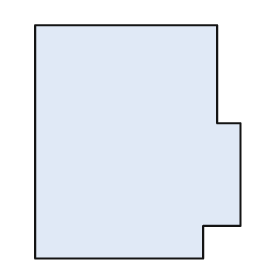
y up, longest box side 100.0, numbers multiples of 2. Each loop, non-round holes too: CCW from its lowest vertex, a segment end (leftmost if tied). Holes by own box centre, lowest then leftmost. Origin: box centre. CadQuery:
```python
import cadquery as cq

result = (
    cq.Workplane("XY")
    .moveTo(-44.0, -50.0)
    .lineTo(28.0, -50.0)
    .lineTo(28.0, -36.0)
    .lineTo(44.0, -36.0)
    .lineTo(44.0, 8.0)
    .lineTo(34.0, 8.0)
    .lineTo(34.0, 50.0)
    .lineTo(-44.0, 50.0)
    .close()
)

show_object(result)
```